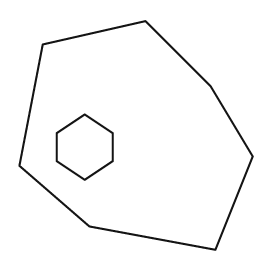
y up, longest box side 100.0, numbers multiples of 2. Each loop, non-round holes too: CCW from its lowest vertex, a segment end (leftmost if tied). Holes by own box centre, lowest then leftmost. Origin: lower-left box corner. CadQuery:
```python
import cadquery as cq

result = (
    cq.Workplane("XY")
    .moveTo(84.0, 0.0)
    .lineTo(100.0, 40.0)
    .lineTo(82.0, 70.0)
    .lineTo(54.0, 98.0)
    .lineTo(10.0, 88.0)
    .lineTo(0.0, 36.0)
    .lineTo(30.0, 10.0)
    .close()
    .moveTo(28.0, 30.0)
    .lineTo(40.0, 38.0)
    .lineTo(40.0, 50.0)
    .lineTo(28.0, 58.0)
    .lineTo(16.0, 50.0)
    .lineTo(16.0, 38.0)
    .close()
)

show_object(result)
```